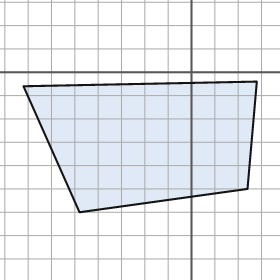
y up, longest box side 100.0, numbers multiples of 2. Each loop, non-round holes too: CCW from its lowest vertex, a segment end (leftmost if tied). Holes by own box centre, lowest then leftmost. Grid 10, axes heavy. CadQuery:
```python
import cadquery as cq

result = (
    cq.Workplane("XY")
    .moveTo(-48.0, -60.0)
    .lineTo(24.0, -50.0)
    .lineTo(28.0, -4.0)
    .lineTo(-72.0, -6.0)
    .close()
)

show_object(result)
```